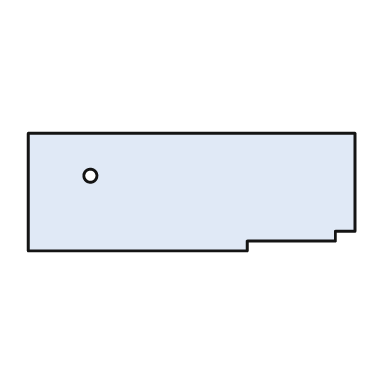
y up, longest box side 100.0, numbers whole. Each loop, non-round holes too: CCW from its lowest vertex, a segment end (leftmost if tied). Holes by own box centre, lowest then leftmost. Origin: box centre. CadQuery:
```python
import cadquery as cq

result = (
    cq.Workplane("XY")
    .moveTo(-50.0, -18.0)
    .lineTo(17.0, -18.0)
    .lineTo(17.0, -15.0)
    .lineTo(44.0, -15.0)
    .lineTo(44.0, -12.0)
    .lineTo(50.0, -12.0)
    .lineTo(50.0, 18.0)
    .lineTo(-50.0, 18.0)
    .close()
    .moveTo(-31.0, 5.0)
    .circle(2.0)
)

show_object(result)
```